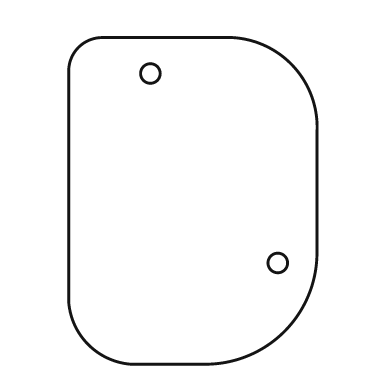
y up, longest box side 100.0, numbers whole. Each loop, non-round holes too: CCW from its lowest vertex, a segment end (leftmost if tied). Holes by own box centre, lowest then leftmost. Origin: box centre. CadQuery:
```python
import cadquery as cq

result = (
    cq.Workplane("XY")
    .moveTo(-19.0, -50.0)
    .lineTo(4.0, -50.0)
    .threePointArc((28.0, -40.0), (38.0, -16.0))
    .lineTo(38.0, 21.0)
    .threePointArc((30.0, 42.0), (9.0, 50.0))
    .lineTo(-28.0, 50.0)
    .threePointArc((-35.0, 47.0), (-38.0, 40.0))
    .lineTo(-38.0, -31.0)
    .threePointArc((-32.0, -44.0), (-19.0, -50.0))
    .close()
    .moveTo(26.0, -19.0)
    .circle(3.0)
    .moveTo(-13.0, 39.0)
    .circle(3.0)
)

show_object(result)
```